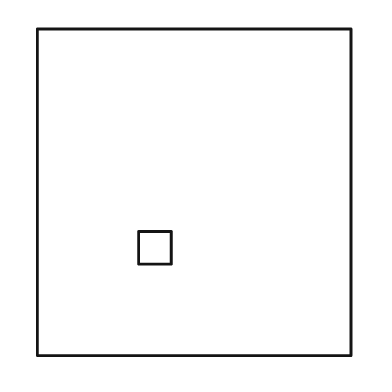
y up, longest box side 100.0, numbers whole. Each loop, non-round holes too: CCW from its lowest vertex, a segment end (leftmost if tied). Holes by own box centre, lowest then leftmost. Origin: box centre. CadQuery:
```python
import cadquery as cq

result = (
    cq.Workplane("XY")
    .moveTo(-48.0, -50.0)
    .lineTo(48.0, -50.0)
    .lineTo(48.0, 50.0)
    .lineTo(-48.0, 50.0)
    .close()
    .moveTo(-17.0, -22.0)
    .lineTo(-7.0, -22.0)
    .lineTo(-7.0, -12.0)
    .lineTo(-17.0, -12.0)
    .close()
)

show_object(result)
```